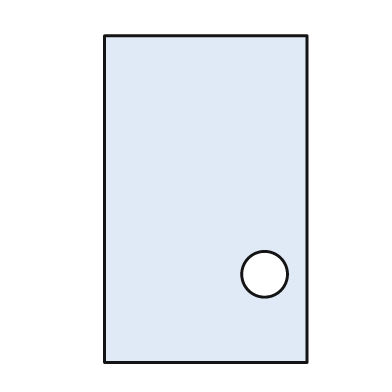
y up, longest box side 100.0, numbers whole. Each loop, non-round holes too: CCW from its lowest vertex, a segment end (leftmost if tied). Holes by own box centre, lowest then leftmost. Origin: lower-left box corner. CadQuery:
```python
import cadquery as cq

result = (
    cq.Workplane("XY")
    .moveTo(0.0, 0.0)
    .lineTo(62.0, 0.0)
    .lineTo(62.0, 100.0)
    .lineTo(0.0, 100.0)
    .close()
    .moveTo(49.0, 27.0)
    .circle(7.0)
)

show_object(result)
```